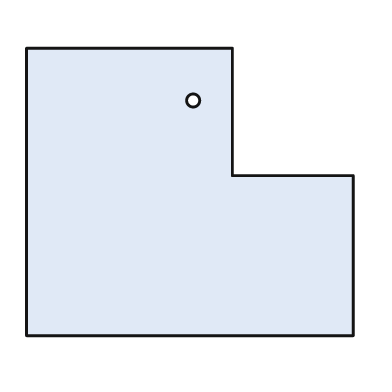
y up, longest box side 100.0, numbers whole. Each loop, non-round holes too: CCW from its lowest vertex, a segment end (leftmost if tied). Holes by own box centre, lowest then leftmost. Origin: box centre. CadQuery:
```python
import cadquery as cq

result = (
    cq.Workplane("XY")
    .moveTo(-50.0, -44.0)
    .lineTo(50.0, -44.0)
    .lineTo(50.0, 5.0)
    .lineTo(13.0, 5.0)
    .lineTo(13.0, 44.0)
    .lineTo(-50.0, 44.0)
    .close()
    .moveTo(1.0, 28.0)
    .circle(2.0)
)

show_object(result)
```